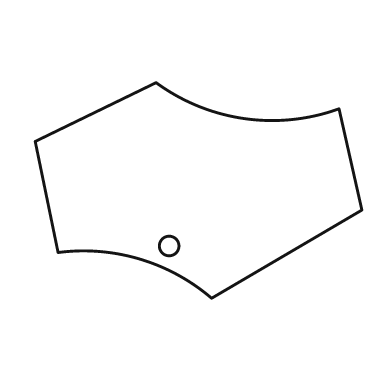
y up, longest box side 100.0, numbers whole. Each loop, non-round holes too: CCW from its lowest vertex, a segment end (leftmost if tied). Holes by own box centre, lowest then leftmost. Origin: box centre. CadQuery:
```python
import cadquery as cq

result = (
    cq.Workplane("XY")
    .moveTo(4.0, -33.0)
    .lineTo(50.0, -6.0)
    .lineTo(43.0, 25.0)
    .threePointArc((14.0, 22.0), (-13.0, 33.0))
    .lineTo(-50.0, 15.0)
    .lineTo(-43.0, -19.0)
    .threePointArc((-18.0, -21.0), (4.0, -33.0))
    .close()
    .moveTo(-9.0, -17.0)
    .circle(3.0)
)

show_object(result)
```